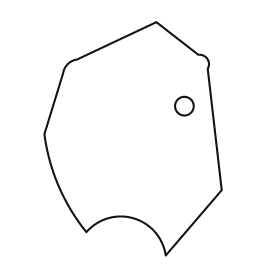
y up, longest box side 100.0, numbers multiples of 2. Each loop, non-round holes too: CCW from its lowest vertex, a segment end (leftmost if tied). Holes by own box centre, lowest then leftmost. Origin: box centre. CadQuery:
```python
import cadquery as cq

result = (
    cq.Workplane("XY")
    .moveTo(14.0, -50.0)
    .lineTo(38.0, -22.0)
    .lineTo(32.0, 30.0)
    .threePointArc((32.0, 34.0), (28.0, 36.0))
    .lineTo(10.0, 50.0)
    .lineTo(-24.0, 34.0)
    .threePointArc((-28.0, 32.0), (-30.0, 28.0))
    .lineTo(-38.0, 2.0)
    .threePointArc((-32.0, -20.0), (-20.0, -40.0))
    .threePointArc((0.0, -34.0), (14.0, -50.0))
    .close()
    .moveTo(22.0, 14.0)
    .circle(4.0)
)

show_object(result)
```